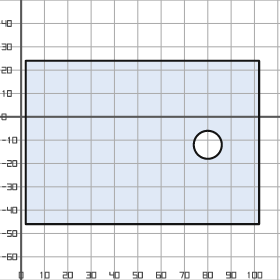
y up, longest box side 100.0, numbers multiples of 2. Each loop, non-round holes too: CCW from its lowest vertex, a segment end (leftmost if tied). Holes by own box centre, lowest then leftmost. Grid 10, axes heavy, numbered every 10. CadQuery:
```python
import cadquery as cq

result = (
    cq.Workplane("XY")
    .moveTo(2.0, -46.0)
    .lineTo(102.0, -46.0)
    .lineTo(102.0, 24.0)
    .lineTo(2.0, 24.0)
    .close()
    .moveTo(80.0, -12.0)
    .circle(6.0)
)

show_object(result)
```